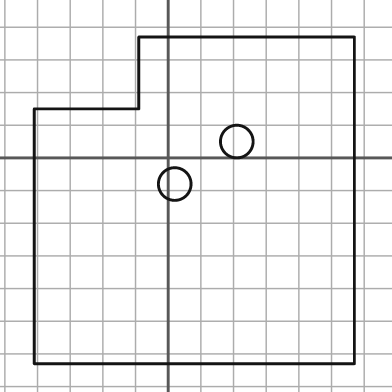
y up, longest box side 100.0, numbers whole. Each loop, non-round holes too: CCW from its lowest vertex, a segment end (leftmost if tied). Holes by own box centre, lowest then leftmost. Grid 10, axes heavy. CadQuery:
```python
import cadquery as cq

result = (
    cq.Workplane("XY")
    .moveTo(-41.0, -63.0)
    .lineTo(57.0, -63.0)
    .lineTo(57.0, 37.0)
    .lineTo(-9.0, 37.0)
    .lineTo(-9.0, 15.0)
    .lineTo(-41.0, 15.0)
    .close()
    .moveTo(2.0, -8.0)
    .circle(5.0)
    .moveTo(21.0, 5.0)
    .circle(5.0)
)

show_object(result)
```